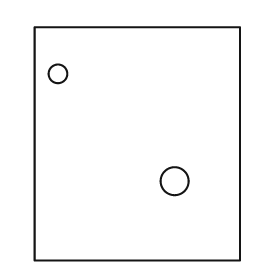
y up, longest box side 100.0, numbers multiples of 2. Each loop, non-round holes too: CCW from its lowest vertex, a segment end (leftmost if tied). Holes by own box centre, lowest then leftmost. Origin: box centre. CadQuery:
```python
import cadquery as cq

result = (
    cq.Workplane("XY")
    .moveTo(-44.0, -50.0)
    .lineTo(44.0, -50.0)
    .lineTo(44.0, 50.0)
    .lineTo(-44.0, 50.0)
    .close()
    .moveTo(16.0, -16.0)
    .circle(6.0)
    .moveTo(-34.0, 30.0)
    .circle(4.0)
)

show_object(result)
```